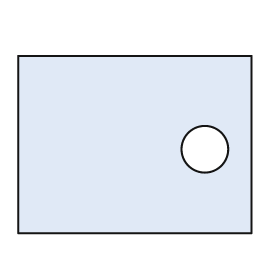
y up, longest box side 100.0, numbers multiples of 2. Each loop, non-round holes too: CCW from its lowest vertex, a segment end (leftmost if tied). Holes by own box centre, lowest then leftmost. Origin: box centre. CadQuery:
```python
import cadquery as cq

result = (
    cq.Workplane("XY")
    .moveTo(-50.0, -38.0)
    .lineTo(50.0, -38.0)
    .lineTo(50.0, 38.0)
    .lineTo(-50.0, 38.0)
    .close()
    .moveTo(30.0, -2.0)
    .circle(10.0)
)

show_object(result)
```